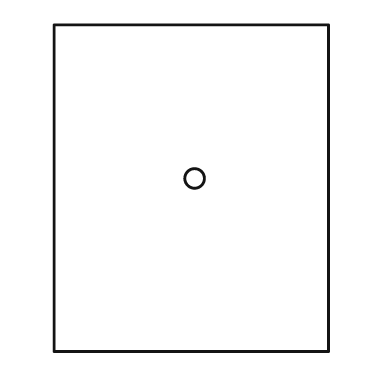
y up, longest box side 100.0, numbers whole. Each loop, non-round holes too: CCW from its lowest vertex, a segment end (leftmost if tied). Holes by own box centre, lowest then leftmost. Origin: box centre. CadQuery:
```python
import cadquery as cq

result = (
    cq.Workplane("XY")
    .moveTo(-42.0, -50.0)
    .lineTo(42.0, -50.0)
    .lineTo(42.0, 50.0)
    .lineTo(-42.0, 50.0)
    .close()
    .moveTo(1.0, 3.0)
    .circle(3.0)
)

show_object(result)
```